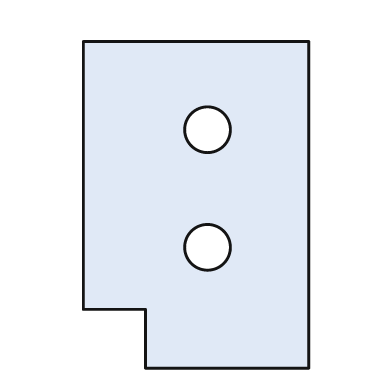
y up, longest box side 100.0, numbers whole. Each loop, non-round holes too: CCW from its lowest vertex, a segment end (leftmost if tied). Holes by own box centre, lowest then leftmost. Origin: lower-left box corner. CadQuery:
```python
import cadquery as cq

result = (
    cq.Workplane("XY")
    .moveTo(19.0, 0.0)
    .lineTo(69.0, 0.0)
    .lineTo(69.0, 100.0)
    .lineTo(0.0, 100.0)
    .lineTo(0.0, 18.0)
    .lineTo(19.0, 18.0)
    .close()
    .moveTo(38.0, 37.0)
    .circle(7.0)
    .moveTo(38.0, 73.0)
    .circle(7.0)
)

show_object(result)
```